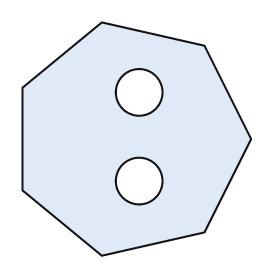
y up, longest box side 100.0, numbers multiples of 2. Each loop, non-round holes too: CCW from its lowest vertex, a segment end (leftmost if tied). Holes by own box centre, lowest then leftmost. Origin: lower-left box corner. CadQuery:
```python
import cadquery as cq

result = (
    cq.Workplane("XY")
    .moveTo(34.0, 0.0)
    .lineTo(78.0, 10.0)
    .lineTo(98.0, 50.0)
    .lineTo(78.0, 90.0)
    .lineTo(34.0, 100.0)
    .lineTo(0.0, 72.0)
    .lineTo(0.0, 28.0)
    .close()
    .moveTo(50.0, 32.0)
    .circle(10.0)
    .moveTo(50.0, 70.0)
    .circle(10.0)
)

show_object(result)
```